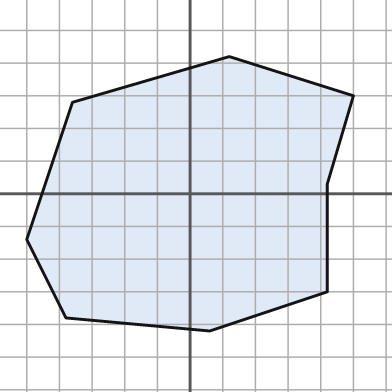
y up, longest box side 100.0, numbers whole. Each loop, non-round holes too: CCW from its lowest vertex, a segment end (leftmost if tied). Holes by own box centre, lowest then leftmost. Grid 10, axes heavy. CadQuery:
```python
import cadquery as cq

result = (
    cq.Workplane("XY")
    .moveTo(6.0, -42.0)
    .lineTo(42.0, -30.0)
    .lineTo(42.0, 3.0)
    .lineTo(50.0, 30.0)
    .lineTo(12.0, 42.0)
    .lineTo(-36.0, 28.0)
    .lineTo(-50.0, -14.0)
    .lineTo(-38.0, -38.0)
    .close()
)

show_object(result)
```